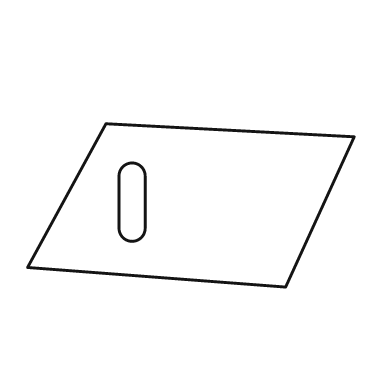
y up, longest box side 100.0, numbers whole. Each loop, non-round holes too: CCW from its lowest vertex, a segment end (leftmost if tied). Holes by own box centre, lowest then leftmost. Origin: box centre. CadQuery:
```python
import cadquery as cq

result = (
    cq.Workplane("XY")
    .moveTo(29.0, -25.0)
    .lineTo(50.0, 21.0)
    .lineTo(-26.0, 25.0)
    .lineTo(-50.0, -19.0)
    .close()
    .moveTo(-22.0, -7.0)
    .threePointArc((-18.0, -11.0), (-14.0, -7.0))
    .lineTo(-14.0, 9.0)
    .threePointArc((-18.0, 13.0), (-22.0, 9.0))
    .close()
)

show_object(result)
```